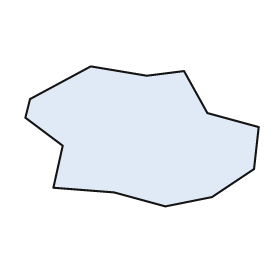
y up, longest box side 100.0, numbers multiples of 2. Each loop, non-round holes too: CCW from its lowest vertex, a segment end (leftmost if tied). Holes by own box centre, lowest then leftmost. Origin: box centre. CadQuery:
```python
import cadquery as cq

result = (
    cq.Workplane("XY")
    .moveTo(10.0, -30.0)
    .lineTo(30.0, -26.0)
    .lineTo(48.0, -14.0)
    .lineTo(50.0, 4.0)
    .lineTo(28.0, 10.0)
    .lineTo(18.0, 28.0)
    .lineTo(2.0, 26.0)
    .lineTo(-22.0, 30.0)
    .lineTo(-48.0, 16.0)
    .lineTo(-50.0, 8.0)
    .lineTo(-34.0, -4.0)
    .lineTo(-38.0, -22.0)
    .lineTo(-12.0, -24.0)
    .close()
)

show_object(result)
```